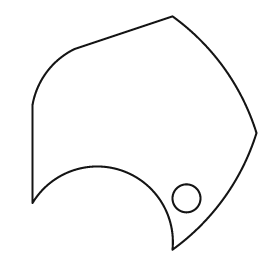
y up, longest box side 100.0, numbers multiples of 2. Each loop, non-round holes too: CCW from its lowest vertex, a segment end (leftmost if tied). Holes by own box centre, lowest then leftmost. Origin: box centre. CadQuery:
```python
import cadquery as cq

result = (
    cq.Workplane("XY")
    .moveTo(12.0, -50.0)
    .threePointArc((34.0, -28.0), (48.0, 0.0))
    .threePointArc((34.0, 28.0), (12.0, 50.0))
    .lineTo(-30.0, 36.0)
    .threePointArc((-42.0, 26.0), (-48.0, 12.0))
    .lineTo(-48.0, -30.0)
    .threePointArc((-10.0, -16.0), (12.0, -50.0))
    .close()
    .moveTo(18.0, -28.0)
    .circle(6.0)
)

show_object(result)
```